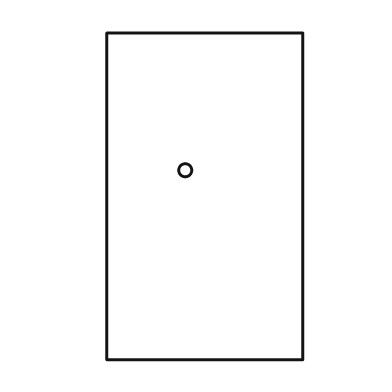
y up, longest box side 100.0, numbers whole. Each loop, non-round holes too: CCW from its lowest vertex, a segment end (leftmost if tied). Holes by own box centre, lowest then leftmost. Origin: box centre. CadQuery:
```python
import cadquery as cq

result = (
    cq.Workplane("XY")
    .moveTo(-30.0, -50.0)
    .lineTo(30.0, -50.0)
    .lineTo(30.0, 50.0)
    .lineTo(-30.0, 50.0)
    .close()
    .moveTo(-6.0, 8.0)
    .circle(2.0)
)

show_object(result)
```